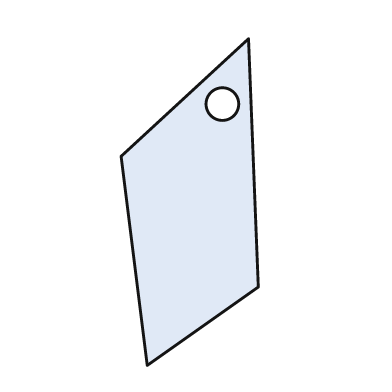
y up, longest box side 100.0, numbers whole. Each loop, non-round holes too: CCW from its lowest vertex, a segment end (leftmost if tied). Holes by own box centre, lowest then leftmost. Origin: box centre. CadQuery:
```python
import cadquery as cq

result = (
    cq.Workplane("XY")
    .moveTo(-13.0, -50.0)
    .lineTo(21.0, -26.0)
    .lineTo(18.0, 50.0)
    .lineTo(-21.0, 14.0)
    .close()
    .moveTo(10.0, 30.0)
    .circle(5.0)
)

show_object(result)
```